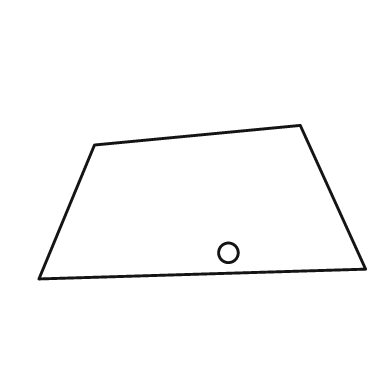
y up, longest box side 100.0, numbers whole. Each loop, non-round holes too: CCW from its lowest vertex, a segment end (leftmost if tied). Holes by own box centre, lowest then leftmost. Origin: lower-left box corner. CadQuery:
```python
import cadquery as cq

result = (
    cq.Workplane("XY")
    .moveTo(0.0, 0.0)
    .lineTo(100.0, 3.0)
    .lineTo(80.0, 47.0)
    .lineTo(17.0, 41.0)
    .close()
    .moveTo(58.0, 8.0)
    .circle(3.0)
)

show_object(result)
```